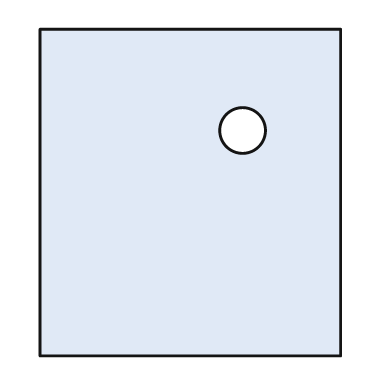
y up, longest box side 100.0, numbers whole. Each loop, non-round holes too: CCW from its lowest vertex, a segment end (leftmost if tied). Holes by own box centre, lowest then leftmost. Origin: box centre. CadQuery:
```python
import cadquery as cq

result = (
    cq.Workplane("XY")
    .moveTo(-46.0, -50.0)
    .lineTo(46.0, -50.0)
    .lineTo(46.0, 50.0)
    .lineTo(-46.0, 50.0)
    .close()
    .moveTo(16.0, 19.0)
    .circle(7.0)
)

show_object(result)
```